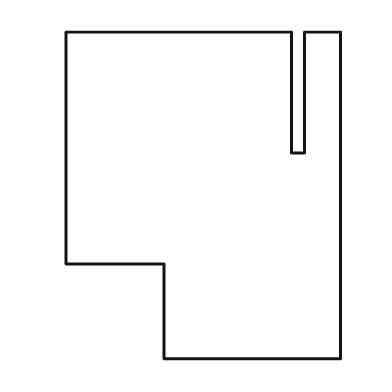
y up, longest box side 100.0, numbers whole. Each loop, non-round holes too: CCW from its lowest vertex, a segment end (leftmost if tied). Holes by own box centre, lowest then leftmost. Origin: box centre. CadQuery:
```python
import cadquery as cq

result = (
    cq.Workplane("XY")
    .moveTo(-12.0, -50.0)
    .lineTo(42.0, -50.0)
    .lineTo(42.0, 50.0)
    .lineTo(31.0, 50.0)
    .lineTo(31.0, 13.0)
    .lineTo(27.0, 13.0)
    .lineTo(27.0, 50.0)
    .lineTo(-42.0, 50.0)
    .lineTo(-42.0, -21.0)
    .lineTo(-12.0, -21.0)
    .close()
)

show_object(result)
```